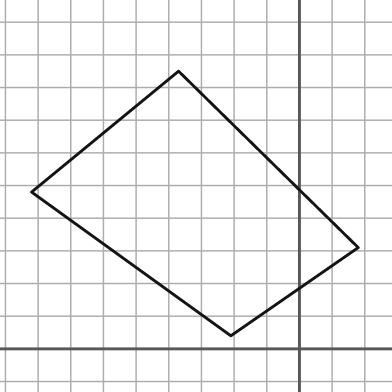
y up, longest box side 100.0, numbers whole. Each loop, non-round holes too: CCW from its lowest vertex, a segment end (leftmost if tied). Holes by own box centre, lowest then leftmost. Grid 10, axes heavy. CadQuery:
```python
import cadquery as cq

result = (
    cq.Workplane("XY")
    .moveTo(-21.0, 4.0)
    .lineTo(18.0, 31.0)
    .lineTo(-37.0, 85.0)
    .lineTo(-82.0, 48.0)
    .close()
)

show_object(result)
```